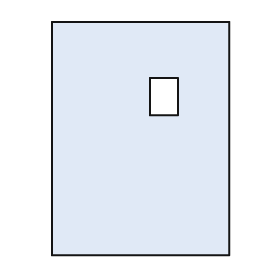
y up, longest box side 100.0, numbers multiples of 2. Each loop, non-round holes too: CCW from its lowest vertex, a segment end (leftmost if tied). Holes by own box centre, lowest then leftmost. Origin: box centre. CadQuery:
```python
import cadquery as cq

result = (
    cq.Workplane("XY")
    .moveTo(-38.0, -50.0)
    .lineTo(38.0, -50.0)
    .lineTo(38.0, 50.0)
    .lineTo(-38.0, 50.0)
    .close()
    .moveTo(4.0, 10.0)
    .lineTo(16.0, 10.0)
    .lineTo(16.0, 26.0)
    .lineTo(4.0, 26.0)
    .close()
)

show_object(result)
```